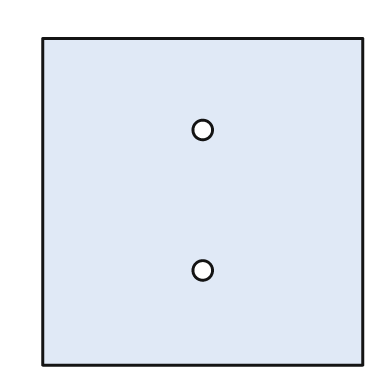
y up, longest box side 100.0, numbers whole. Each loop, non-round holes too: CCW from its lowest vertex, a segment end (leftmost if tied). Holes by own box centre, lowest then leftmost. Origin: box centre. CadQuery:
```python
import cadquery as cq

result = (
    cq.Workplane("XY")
    .moveTo(-49.0, -50.0)
    .lineTo(49.0, -50.0)
    .lineTo(49.0, 50.0)
    .lineTo(-49.0, 50.0)
    .close()
    .moveTo(0.0, -21.0)
    .circle(3.0)
    .moveTo(0.0, 22.0)
    .circle(3.0)
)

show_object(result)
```